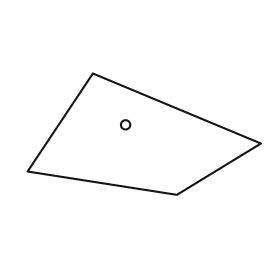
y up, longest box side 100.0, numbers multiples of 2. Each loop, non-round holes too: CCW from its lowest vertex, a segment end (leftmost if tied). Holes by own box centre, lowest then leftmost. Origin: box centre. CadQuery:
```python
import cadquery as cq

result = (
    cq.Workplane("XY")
    .moveTo(14.0, -26.0)
    .lineTo(50.0, -4.0)
    .lineTo(-22.0, 26.0)
    .lineTo(-50.0, -16.0)
    .close()
    .moveTo(-8.0, 4.0)
    .circle(2.0)
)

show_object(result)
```